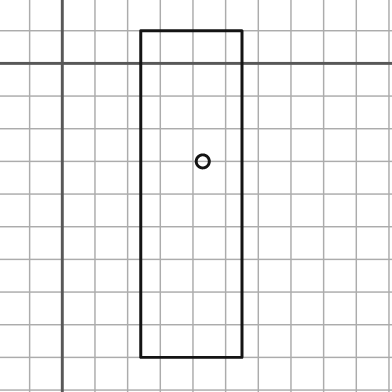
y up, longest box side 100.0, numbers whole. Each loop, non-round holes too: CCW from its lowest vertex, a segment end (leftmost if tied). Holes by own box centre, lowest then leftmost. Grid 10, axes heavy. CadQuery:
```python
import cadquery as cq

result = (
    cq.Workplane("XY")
    .moveTo(24.0, -90.0)
    .lineTo(55.0, -90.0)
    .lineTo(55.0, 10.0)
    .lineTo(24.0, 10.0)
    .close()
    .moveTo(43.0, -30.0)
    .circle(2.0)
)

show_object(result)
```